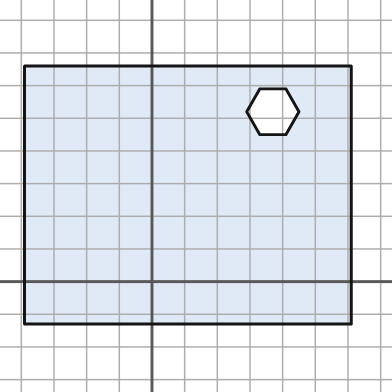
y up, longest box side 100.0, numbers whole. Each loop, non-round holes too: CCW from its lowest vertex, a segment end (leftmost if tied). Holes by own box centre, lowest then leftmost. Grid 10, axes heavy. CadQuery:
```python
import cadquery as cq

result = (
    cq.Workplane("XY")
    .moveTo(-39.0, -13.0)
    .lineTo(61.0, -13.0)
    .lineTo(61.0, 66.0)
    .lineTo(-39.0, 66.0)
    .close()
    .moveTo(33.0, 45.0)
    .lineTo(41.0, 45.0)
    .lineTo(45.0, 52.0)
    .lineTo(41.0, 59.0)
    .lineTo(33.0, 59.0)
    .lineTo(29.0, 52.0)
    .close()
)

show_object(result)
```